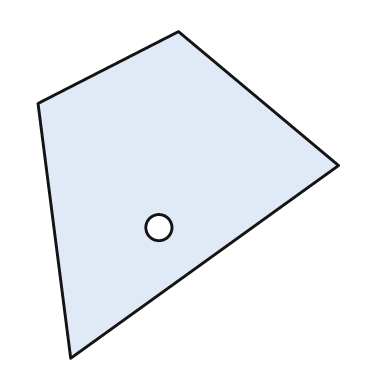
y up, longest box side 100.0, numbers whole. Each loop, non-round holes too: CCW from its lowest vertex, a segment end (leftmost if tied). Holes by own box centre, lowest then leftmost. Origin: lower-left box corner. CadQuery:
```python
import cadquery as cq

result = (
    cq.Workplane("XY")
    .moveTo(10.0, 0.0)
    .lineTo(92.0, 59.0)
    .lineTo(43.0, 100.0)
    .lineTo(0.0, 78.0)
    .close()
    .moveTo(37.0, 40.0)
    .circle(4.0)
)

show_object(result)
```